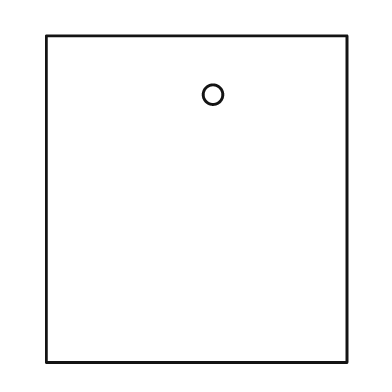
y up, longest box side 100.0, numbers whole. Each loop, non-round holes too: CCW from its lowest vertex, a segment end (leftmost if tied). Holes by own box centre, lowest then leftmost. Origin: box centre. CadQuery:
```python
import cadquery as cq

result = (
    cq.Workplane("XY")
    .moveTo(-46.0, -50.0)
    .lineTo(46.0, -50.0)
    .lineTo(46.0, 50.0)
    .lineTo(-46.0, 50.0)
    .close()
    .moveTo(5.0, 32.0)
    .circle(3.0)
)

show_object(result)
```